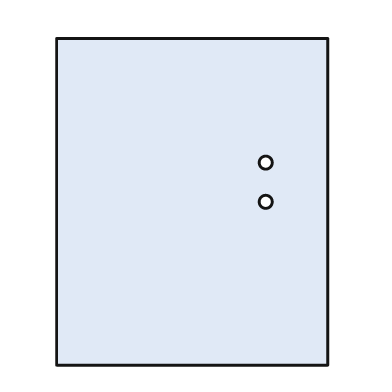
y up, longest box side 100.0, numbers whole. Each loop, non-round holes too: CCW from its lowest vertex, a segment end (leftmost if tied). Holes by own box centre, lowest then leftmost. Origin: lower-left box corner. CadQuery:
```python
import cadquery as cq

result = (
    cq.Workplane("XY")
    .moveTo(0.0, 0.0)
    .lineTo(83.0, 0.0)
    .lineTo(83.0, 100.0)
    .lineTo(0.0, 100.0)
    .close()
    .moveTo(64.0, 50.0)
    .circle(2.0)
    .moveTo(64.0, 62.0)
    .circle(2.0)
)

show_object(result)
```